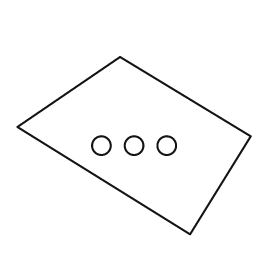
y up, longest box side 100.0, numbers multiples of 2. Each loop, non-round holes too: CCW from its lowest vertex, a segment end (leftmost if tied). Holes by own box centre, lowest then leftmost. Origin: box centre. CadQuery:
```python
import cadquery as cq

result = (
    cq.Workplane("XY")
    .moveTo(24.0, -38.0)
    .lineTo(50.0, 4.0)
    .lineTo(-6.0, 38.0)
    .lineTo(-50.0, 8.0)
    .close()
    .moveTo(-14.0, 0.0)
    .circle(4.0)
    .moveTo(0.0, 0.0)
    .circle(4.0)
    .moveTo(14.0, 0.0)
    .circle(4.0)
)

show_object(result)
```